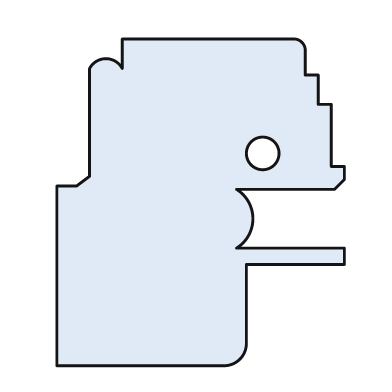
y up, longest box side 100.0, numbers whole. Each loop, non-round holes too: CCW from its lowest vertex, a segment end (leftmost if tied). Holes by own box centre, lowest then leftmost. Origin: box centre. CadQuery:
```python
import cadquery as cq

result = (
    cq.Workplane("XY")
    .moveTo(-44.0, -50.0)
    .lineTo(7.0, -50.0)
    .threePointArc((12.0, -48.0), (14.0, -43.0))
    .lineTo(14.0, -19.0)
    .lineTo(44.0, -19.0)
    .lineTo(44.0, -14.0)
    .lineTo(11.0, -14.0)
    .threePointArc((16.0, -5.0), (11.0, 4.0))
    .lineTo(41.0, 4.0)
    .lineTo(44.0, 7.0)
    .lineTo(44.0, 11.0)
    .lineTo(40.0, 11.0)
    .lineTo(40.0, 30.0)
    .lineTo(36.0, 30.0)
    .lineTo(36.0, 39.0)
    .lineTo(32.0, 39.0)
    .lineTo(32.0, 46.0)
    .threePointArc((31.0, 49.0), (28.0, 50.0))
    .lineTo(-24.0, 50.0)
    .lineTo(-24.0, 41.0)
    .threePointArc((-29.0, 44.0), (-34.0, 41.0))
    .lineTo(-34.0, 8.0)
    .lineTo(-38.0, 5.0)
    .lineTo(-44.0, 5.0)
    .close()
    .moveTo(19.0, 15.0)
    .circle(5.0)
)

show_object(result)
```